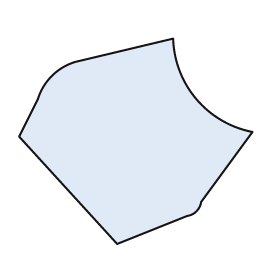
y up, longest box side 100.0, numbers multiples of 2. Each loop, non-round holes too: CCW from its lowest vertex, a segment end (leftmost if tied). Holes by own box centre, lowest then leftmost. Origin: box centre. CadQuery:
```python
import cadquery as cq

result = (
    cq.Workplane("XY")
    .moveTo(-8.0, -44.0)
    .lineTo(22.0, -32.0)
    .threePointArc((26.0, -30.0), (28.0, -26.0))
    .lineTo(50.0, 4.0)
    .threePointArc((26.0, 18.0), (16.0, 44.0))
    .lineTo(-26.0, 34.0)
    .threePointArc((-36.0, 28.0), (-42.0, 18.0))
    .lineTo(-50.0, 2.0)
    .close()
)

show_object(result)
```